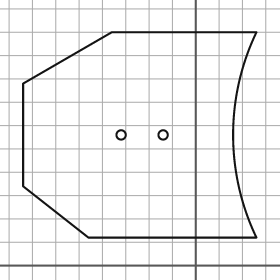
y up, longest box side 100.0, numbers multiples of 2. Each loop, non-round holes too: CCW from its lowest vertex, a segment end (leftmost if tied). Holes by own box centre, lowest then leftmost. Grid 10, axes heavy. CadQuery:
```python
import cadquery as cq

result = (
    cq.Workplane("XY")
    .moveTo(-46.0, 12.0)
    .lineTo(26.0, 12.0)
    .threePointArc((16.0, 56.0), (26.0, 100.0))
    .lineTo(-36.0, 100.0)
    .lineTo(-74.0, 78.0)
    .lineTo(-74.0, 34.0)
    .close()
    .moveTo(-32.0, 56.0)
    .circle(2.0)
    .moveTo(-14.0, 56.0)
    .circle(2.0)
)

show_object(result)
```